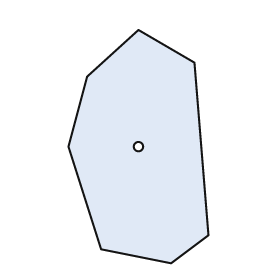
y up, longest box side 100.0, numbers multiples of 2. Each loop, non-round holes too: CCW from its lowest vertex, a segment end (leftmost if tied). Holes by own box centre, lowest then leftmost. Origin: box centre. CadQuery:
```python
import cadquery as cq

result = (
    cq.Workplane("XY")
    .moveTo(14.0, -50.0)
    .lineTo(30.0, -38.0)
    .lineTo(24.0, 36.0)
    .lineTo(0.0, 50.0)
    .lineTo(-22.0, 30.0)
    .lineTo(-30.0, 0.0)
    .lineTo(-16.0, -44.0)
    .close()
    .moveTo(0.0, 0.0)
    .circle(2.0)
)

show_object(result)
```